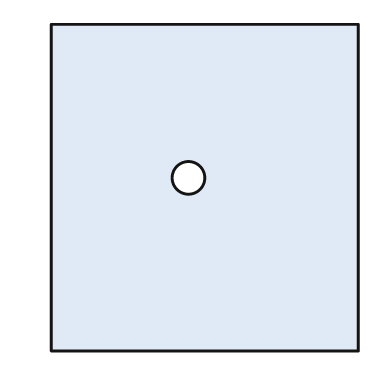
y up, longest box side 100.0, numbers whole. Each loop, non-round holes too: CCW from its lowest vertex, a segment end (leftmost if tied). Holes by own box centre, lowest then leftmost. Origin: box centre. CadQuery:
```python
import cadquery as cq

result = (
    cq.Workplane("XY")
    .moveTo(-47.0, -50.0)
    .lineTo(47.0, -50.0)
    .lineTo(47.0, 50.0)
    .lineTo(-47.0, 50.0)
    .close()
    .moveTo(-5.0, 3.0)
    .circle(5.0)
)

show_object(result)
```